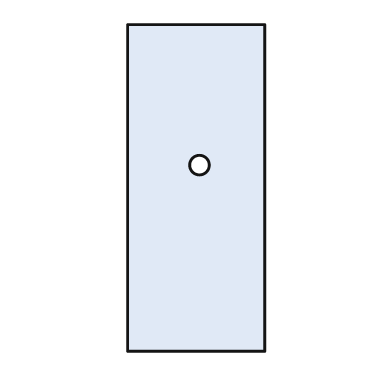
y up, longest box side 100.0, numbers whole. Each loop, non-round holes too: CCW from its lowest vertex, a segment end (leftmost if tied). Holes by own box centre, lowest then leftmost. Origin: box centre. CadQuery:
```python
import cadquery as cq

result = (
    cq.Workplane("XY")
    .moveTo(-21.0, -50.0)
    .lineTo(21.0, -50.0)
    .lineTo(21.0, 50.0)
    .lineTo(-21.0, 50.0)
    .close()
    .moveTo(1.0, 7.0)
    .circle(3.0)
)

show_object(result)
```